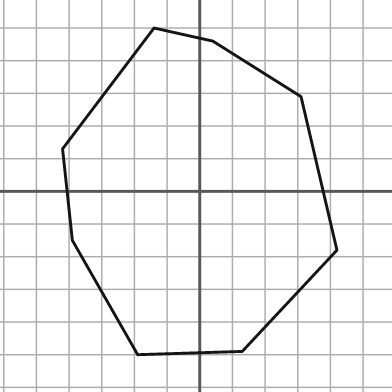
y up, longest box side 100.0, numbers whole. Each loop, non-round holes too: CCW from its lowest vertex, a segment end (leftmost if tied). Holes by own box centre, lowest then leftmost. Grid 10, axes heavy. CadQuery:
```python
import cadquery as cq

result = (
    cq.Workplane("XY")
    .moveTo(-19.0, -50.0)
    .lineTo(13.0, -49.0)
    .lineTo(42.0, -18.0)
    .lineTo(31.0, 29.0)
    .lineTo(4.0, 46.0)
    .lineTo(-14.0, 50.0)
    .lineTo(-42.0, 13.0)
    .lineTo(-39.0, -15.0)
    .close()
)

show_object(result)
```